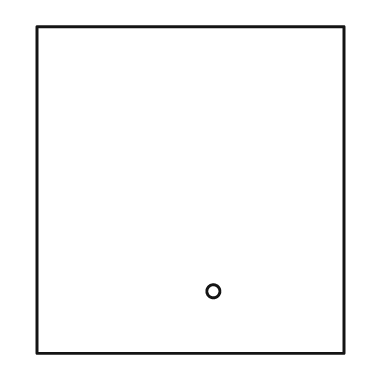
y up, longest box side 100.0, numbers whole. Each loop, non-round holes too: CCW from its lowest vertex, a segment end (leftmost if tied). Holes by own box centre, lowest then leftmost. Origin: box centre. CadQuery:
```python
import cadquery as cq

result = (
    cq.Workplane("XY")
    .moveTo(-47.0, -50.0)
    .lineTo(47.0, -50.0)
    .lineTo(47.0, 50.0)
    .lineTo(-47.0, 50.0)
    .close()
    .moveTo(7.0, -31.0)
    .circle(2.0)
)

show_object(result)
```